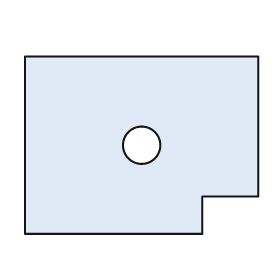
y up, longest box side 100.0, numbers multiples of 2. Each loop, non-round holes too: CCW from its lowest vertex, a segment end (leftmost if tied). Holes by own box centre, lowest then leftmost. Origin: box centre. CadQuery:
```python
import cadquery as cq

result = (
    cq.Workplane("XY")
    .moveTo(-50.0, -38.0)
    .lineTo(26.0, -38.0)
    .lineTo(26.0, -22.0)
    .lineTo(50.0, -22.0)
    .lineTo(50.0, 38.0)
    .lineTo(-50.0, 38.0)
    .close()
    .moveTo(0.0, 0.0)
    .circle(8.0)
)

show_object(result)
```